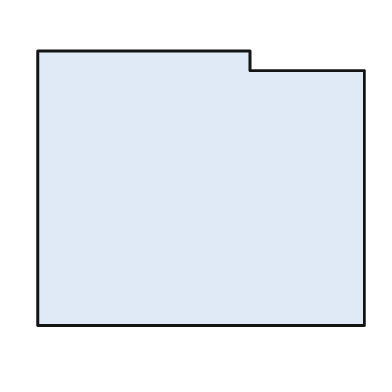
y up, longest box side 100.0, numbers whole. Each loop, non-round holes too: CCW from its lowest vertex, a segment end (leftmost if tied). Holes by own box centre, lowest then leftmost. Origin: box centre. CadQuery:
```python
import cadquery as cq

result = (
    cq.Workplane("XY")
    .moveTo(-50.0, -42.0)
    .lineTo(50.0, -42.0)
    .lineTo(50.0, 36.0)
    .lineTo(15.0, 36.0)
    .lineTo(15.0, 42.0)
    .lineTo(-50.0, 42.0)
    .close()
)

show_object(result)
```